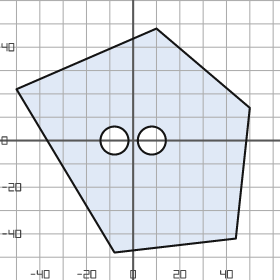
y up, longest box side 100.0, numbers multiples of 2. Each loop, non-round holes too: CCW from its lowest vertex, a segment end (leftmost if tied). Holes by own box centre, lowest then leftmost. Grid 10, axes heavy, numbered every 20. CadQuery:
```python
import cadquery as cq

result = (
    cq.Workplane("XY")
    .moveTo(-8.0, -48.0)
    .lineTo(44.0, -42.0)
    .lineTo(50.0, 14.0)
    .lineTo(10.0, 48.0)
    .lineTo(-50.0, 22.0)
    .close()
    .moveTo(-8.0, 0.0)
    .circle(6.0)
    .moveTo(8.0, 0.0)
    .circle(6.0)
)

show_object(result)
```